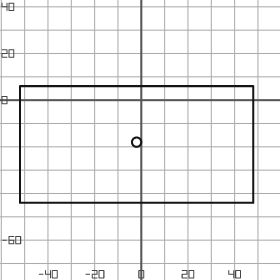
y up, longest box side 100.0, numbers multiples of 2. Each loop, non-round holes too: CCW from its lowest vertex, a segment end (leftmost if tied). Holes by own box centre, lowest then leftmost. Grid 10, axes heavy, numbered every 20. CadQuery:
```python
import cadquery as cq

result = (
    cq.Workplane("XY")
    .moveTo(-52.0, -44.0)
    .lineTo(48.0, -44.0)
    .lineTo(48.0, 6.0)
    .lineTo(-52.0, 6.0)
    .close()
    .moveTo(-2.0, -18.0)
    .circle(2.0)
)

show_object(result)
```